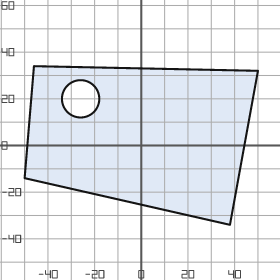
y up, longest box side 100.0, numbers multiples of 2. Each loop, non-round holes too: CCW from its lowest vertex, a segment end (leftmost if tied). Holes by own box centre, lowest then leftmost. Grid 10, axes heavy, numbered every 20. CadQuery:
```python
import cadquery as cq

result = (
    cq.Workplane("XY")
    .moveTo(38.0, -34.0)
    .lineTo(50.0, 32.0)
    .lineTo(-46.0, 34.0)
    .lineTo(-50.0, -14.0)
    .close()
    .moveTo(-26.0, 20.0)
    .circle(8.0)
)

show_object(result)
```